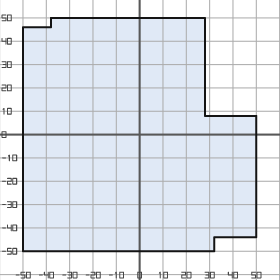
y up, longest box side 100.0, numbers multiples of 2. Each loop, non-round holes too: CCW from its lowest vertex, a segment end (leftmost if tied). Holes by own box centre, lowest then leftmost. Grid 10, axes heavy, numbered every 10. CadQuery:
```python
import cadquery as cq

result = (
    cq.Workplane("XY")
    .moveTo(-50.0, -50.0)
    .lineTo(32.0, -50.0)
    .lineTo(32.0, -44.0)
    .lineTo(50.0, -44.0)
    .lineTo(50.0, 8.0)
    .lineTo(28.0, 8.0)
    .lineTo(28.0, 50.0)
    .lineTo(-38.0, 50.0)
    .lineTo(-38.0, 46.0)
    .lineTo(-50.0, 46.0)
    .close()
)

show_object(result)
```